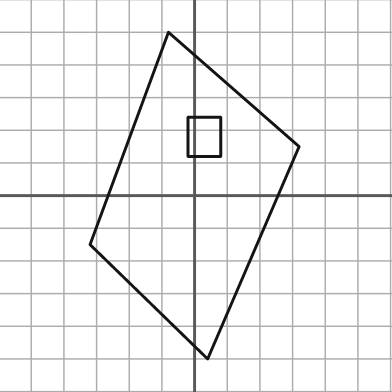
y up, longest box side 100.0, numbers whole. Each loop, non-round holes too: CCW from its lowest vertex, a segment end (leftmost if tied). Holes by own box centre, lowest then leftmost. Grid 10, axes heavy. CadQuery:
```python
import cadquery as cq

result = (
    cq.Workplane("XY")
    .moveTo(4.0, -50.0)
    .lineTo(32.0, 15.0)
    .lineTo(-8.0, 50.0)
    .lineTo(-32.0, -15.0)
    .close()
    .moveTo(-2.0, 12.0)
    .lineTo(8.0, 12.0)
    .lineTo(8.0, 24.0)
    .lineTo(-2.0, 24.0)
    .close()
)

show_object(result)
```